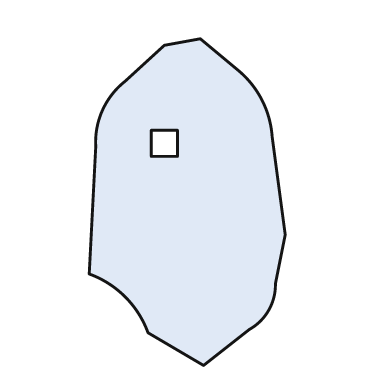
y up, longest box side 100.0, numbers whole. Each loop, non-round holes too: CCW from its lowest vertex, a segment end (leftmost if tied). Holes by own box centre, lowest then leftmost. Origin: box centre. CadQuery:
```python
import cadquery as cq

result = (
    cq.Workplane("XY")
    .moveTo(5.0, -50.0)
    .lineTo(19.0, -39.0)
    .threePointArc((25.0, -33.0), (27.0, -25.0))
    .lineTo(30.0, -10.0)
    .lineTo(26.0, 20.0)
    .threePointArc((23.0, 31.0), (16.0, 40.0))
    .lineTo(4.0, 50.0)
    .lineTo(-7.0, 48.0)
    .lineTo(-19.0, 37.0)
    .threePointArc((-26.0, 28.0), (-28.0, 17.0))
    .lineTo(-30.0, -22.0)
    .threePointArc((-19.0, -29.0), (-12.0, -40.0))
    .close()
    .moveTo(-11.0, 14.0)
    .lineTo(-3.0, 14.0)
    .lineTo(-3.0, 22.0)
    .lineTo(-11.0, 22.0)
    .close()
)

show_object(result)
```